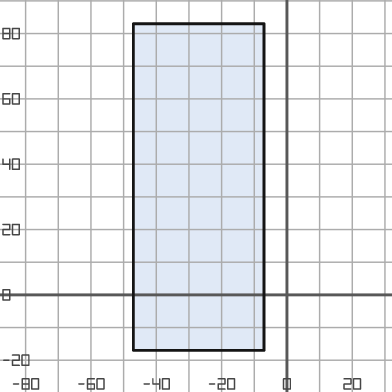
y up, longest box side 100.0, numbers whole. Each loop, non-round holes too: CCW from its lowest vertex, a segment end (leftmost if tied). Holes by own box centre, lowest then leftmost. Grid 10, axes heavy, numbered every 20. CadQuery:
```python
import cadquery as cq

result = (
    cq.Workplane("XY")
    .moveTo(-47.0, -17.0)
    .lineTo(-7.0, -17.0)
    .lineTo(-7.0, 83.0)
    .lineTo(-47.0, 83.0)
    .close()
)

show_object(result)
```